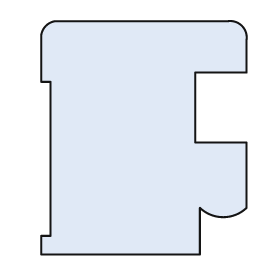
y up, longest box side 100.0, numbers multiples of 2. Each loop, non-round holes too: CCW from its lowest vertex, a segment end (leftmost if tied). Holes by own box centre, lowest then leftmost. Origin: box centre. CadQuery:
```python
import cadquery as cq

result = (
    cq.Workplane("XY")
    .moveTo(-44.0, -50.0)
    .lineTo(24.0, -50.0)
    .lineTo(24.0, -30.0)
    .threePointArc((34.0, -34.0), (44.0, -30.0))
    .lineTo(44.0, -2.0)
    .lineTo(22.0, -2.0)
    .lineTo(22.0, 28.0)
    .lineTo(44.0, 28.0)
    .lineTo(44.0, 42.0)
    .threePointArc((42.0, 48.0), (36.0, 50.0))
    .lineTo(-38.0, 50.0)
    .threePointArc((-42.0, 48.0), (-44.0, 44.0))
    .lineTo(-44.0, 24.0)
    .lineTo(-40.0, 24.0)
    .lineTo(-40.0, -42.0)
    .lineTo(-44.0, -42.0)
    .close()
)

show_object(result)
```